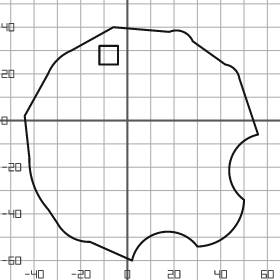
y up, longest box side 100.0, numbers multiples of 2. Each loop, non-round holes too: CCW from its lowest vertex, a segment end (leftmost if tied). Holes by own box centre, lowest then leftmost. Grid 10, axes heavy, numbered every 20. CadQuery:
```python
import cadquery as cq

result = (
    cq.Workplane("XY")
    .moveTo(2.0, -60.0)
    .threePointArc((14.0, -48.0), (30.0, -54.0))
    .threePointArc((44.0, -48.0), (50.0, -34.0))
    .threePointArc((44.0, -18.0), (56.0, -6.0))
    .lineTo(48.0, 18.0)
    .threePointArc((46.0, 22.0), (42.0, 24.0))
    .lineTo(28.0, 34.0)
    .threePointArc((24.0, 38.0), (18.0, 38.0))
    .lineTo(-6.0, 40.0)
    .lineTo(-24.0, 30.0)
    .threePointArc((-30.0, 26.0), (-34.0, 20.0))
    .lineTo(-44.0, 2.0)
    .lineTo(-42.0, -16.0)
    .threePointArc((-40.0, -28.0), (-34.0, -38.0))
    .lineTo(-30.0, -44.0)
    .threePointArc((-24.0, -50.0), (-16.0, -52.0))
    .close()
    .moveTo(-12.0, 24.0)
    .lineTo(-4.0, 24.0)
    .lineTo(-4.0, 32.0)
    .lineTo(-12.0, 32.0)
    .close()
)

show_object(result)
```